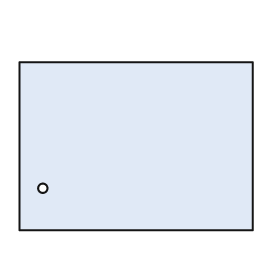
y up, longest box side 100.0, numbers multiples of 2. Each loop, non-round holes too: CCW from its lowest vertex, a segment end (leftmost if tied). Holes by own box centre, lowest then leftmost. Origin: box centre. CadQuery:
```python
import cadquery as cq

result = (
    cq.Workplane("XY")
    .moveTo(-50.0, -36.0)
    .lineTo(50.0, -36.0)
    .lineTo(50.0, 36.0)
    .lineTo(-50.0, 36.0)
    .close()
    .moveTo(-40.0, -18.0)
    .circle(2.0)
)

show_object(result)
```